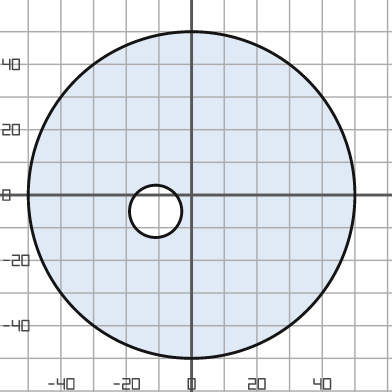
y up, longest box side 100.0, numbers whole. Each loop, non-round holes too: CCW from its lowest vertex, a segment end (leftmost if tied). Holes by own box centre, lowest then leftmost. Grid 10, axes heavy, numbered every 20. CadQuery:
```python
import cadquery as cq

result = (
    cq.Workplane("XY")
    .moveTo(0.0, 0.0)
    .circle(50.0)
    .moveTo(-11.0, -5.0)
    .circle(8.0)
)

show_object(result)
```